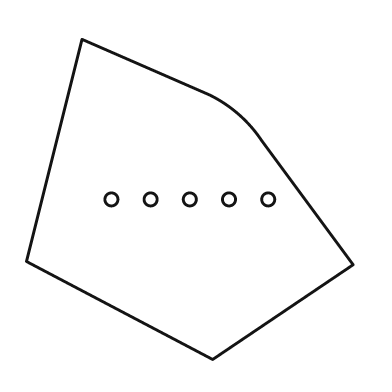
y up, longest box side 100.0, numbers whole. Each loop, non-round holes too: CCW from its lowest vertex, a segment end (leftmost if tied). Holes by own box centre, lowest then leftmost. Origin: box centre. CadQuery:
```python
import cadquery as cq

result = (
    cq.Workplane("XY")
    .moveTo(7.0, -49.0)
    .lineTo(50.0, -20.0)
    .lineTo(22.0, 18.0)
    .threePointArc((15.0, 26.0), (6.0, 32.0))
    .lineTo(-33.0, 49.0)
    .lineTo(-50.0, -19.0)
    .close()
    .moveTo(-24.0, 0.0)
    .circle(2.0)
    .moveTo(-12.0, 0.0)
    .circle(2.0)
    .moveTo(0.0, 0.0)
    .circle(2.0)
    .moveTo(12.0, 0.0)
    .circle(2.0)
    .moveTo(24.0, 0.0)
    .circle(2.0)
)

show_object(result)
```